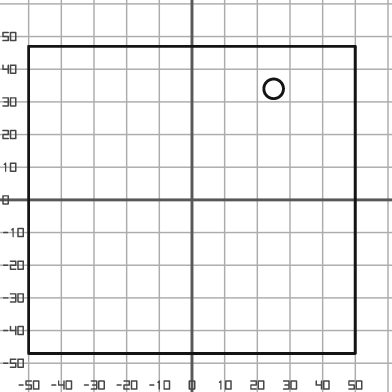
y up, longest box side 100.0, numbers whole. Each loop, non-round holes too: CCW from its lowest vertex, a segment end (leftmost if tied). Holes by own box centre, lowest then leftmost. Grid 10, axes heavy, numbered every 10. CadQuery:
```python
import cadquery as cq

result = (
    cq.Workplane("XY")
    .moveTo(-50.0, -47.0)
    .lineTo(50.0, -47.0)
    .lineTo(50.0, 47.0)
    .lineTo(-50.0, 47.0)
    .close()
    .moveTo(25.0, 34.0)
    .circle(3.0)
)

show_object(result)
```